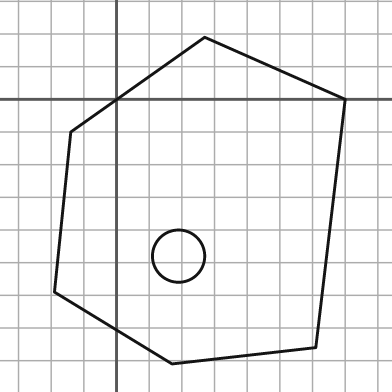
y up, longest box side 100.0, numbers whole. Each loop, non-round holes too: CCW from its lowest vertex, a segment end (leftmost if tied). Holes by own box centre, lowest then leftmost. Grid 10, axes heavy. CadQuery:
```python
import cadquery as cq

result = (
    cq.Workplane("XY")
    .moveTo(17.0, -81.0)
    .lineTo(61.0, -76.0)
    .lineTo(70.0, 0.0)
    .lineTo(27.0, 19.0)
    .lineTo(-14.0, -10.0)
    .lineTo(-19.0, -59.0)
    .close()
    .moveTo(19.0, -48.0)
    .circle(8.0)
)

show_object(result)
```